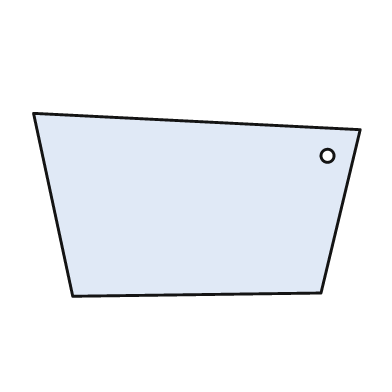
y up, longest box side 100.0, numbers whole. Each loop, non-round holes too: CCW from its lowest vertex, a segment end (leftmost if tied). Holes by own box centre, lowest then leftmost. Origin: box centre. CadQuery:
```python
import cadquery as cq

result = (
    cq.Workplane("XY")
    .moveTo(-38.0, -28.0)
    .lineTo(38.0, -27.0)
    .lineTo(50.0, 23.0)
    .lineTo(-50.0, 28.0)
    .close()
    .moveTo(40.0, 15.0)
    .circle(2.0)
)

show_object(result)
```